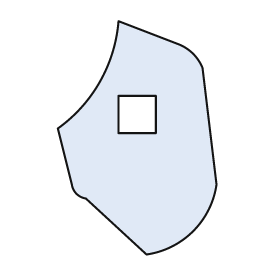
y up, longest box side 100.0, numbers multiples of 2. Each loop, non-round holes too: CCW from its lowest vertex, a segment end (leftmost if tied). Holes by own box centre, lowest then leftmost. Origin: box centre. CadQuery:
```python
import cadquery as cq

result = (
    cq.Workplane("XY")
    .moveTo(4.0, -50.0)
    .threePointArc((24.0, -40.0), (34.0, -20.0))
    .lineTo(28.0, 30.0)
    .threePointArc((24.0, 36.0), (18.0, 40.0))
    .lineTo(-8.0, 50.0)
    .threePointArc((-16.0, 24.0), (-34.0, 4.0))
    .lineTo(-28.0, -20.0)
    .threePointArc((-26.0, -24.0), (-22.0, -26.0))
    .close()
    .moveTo(-8.0, 2.0)
    .lineTo(8.0, 2.0)
    .lineTo(8.0, 18.0)
    .lineTo(-8.0, 18.0)
    .close()
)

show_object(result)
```